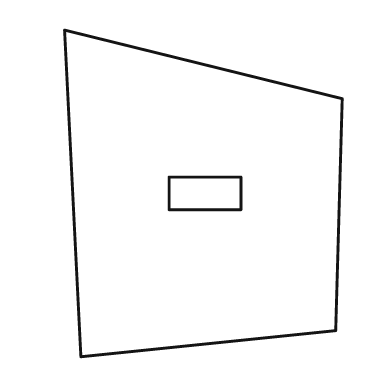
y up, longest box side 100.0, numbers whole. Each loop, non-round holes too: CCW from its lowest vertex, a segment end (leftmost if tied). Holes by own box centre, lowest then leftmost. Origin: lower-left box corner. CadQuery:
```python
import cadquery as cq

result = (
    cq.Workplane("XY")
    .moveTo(5.0, 0.0)
    .lineTo(83.0, 8.0)
    .lineTo(85.0, 79.0)
    .lineTo(0.0, 100.0)
    .close()
    .moveTo(32.0, 45.0)
    .lineTo(54.0, 45.0)
    .lineTo(54.0, 55.0)
    .lineTo(32.0, 55.0)
    .close()
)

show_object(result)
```